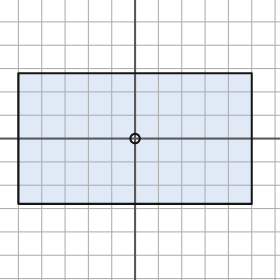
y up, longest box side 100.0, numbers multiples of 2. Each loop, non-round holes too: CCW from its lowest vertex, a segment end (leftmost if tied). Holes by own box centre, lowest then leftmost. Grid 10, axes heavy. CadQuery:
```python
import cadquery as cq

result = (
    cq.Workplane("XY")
    .moveTo(-50.0, -28.0)
    .lineTo(50.0, -28.0)
    .lineTo(50.0, 28.0)
    .lineTo(-50.0, 28.0)
    .close()
    .moveTo(0.0, 0.0)
    .circle(2.0)
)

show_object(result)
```